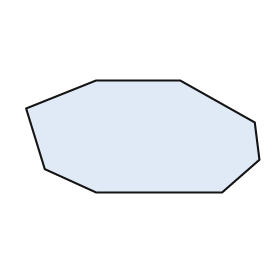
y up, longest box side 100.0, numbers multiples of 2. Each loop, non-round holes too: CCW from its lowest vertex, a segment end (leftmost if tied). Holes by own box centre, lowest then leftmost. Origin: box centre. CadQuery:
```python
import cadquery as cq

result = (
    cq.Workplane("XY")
    .moveTo(-20.0, -24.0)
    .lineTo(34.0, -24.0)
    .lineTo(50.0, -10.0)
    .lineTo(48.0, 6.0)
    .lineTo(16.0, 24.0)
    .lineTo(-20.0, 24.0)
    .lineTo(-50.0, 12.0)
    .lineTo(-42.0, -14.0)
    .close()
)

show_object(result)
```